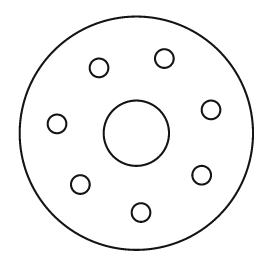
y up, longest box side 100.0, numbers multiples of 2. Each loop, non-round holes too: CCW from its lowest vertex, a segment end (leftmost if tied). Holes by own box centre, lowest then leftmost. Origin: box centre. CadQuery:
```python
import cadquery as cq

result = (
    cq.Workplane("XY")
    .moveTo(0.0, 0.0)
    .circle(50.0)
    .moveTo(2.0, -34.0)
    .circle(4.0)
    .moveTo(-24.0, -22.0)
    .circle(4.0)
    .moveTo(28.0, -18.0)
    .circle(4.0)
    .moveTo(0.0, 0.0)
    .circle(14.0)
    .moveTo(-34.0, 4.0)
    .circle(4.0)
    .moveTo(32.0, 10.0)
    .circle(4.0)
    .moveTo(-16.0, 28.0)
    .circle(4.0)
    .moveTo(12.0, 32.0)
    .circle(4.0)
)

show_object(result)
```